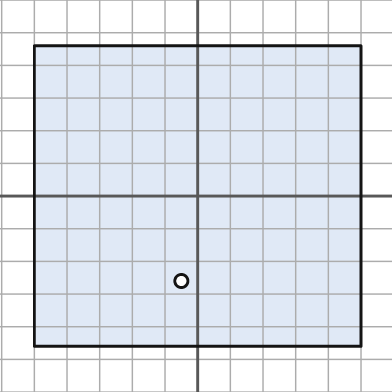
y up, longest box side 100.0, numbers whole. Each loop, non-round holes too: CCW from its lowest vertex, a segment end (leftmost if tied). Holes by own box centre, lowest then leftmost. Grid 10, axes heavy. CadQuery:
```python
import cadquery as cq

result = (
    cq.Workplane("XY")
    .moveTo(-50.0, -46.0)
    .lineTo(50.0, -46.0)
    .lineTo(50.0, 46.0)
    .lineTo(-50.0, 46.0)
    .close()
    .moveTo(-5.0, -26.0)
    .circle(2.0)
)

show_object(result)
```